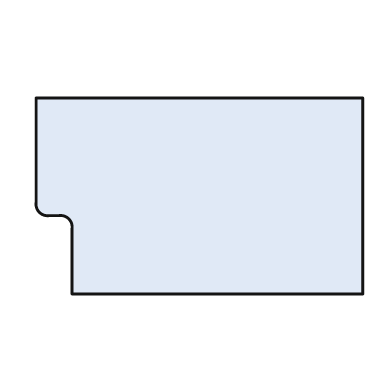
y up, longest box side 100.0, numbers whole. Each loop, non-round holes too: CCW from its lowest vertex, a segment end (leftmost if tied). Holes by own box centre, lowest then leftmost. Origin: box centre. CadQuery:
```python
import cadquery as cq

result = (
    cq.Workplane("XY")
    .moveTo(-39.0, -30.0)
    .lineTo(50.0, -30.0)
    .lineTo(50.0, 30.0)
    .lineTo(-50.0, 30.0)
    .lineTo(-50.0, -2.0)
    .threePointArc((-49.0, -5.0), (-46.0, -6.0))
    .lineTo(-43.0, -6.0)
    .threePointArc((-40.0, -7.0), (-39.0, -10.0))
    .close()
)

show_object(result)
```